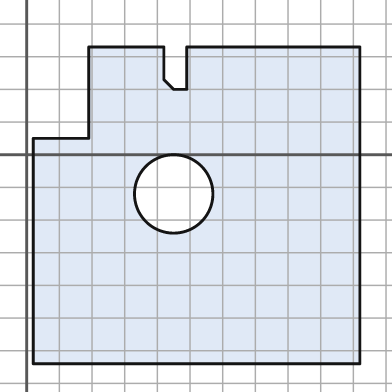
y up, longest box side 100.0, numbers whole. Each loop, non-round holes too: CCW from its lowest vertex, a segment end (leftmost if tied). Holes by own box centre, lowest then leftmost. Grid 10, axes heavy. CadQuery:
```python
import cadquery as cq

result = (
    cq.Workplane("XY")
    .moveTo(2.0, -64.0)
    .lineTo(102.0, -64.0)
    .lineTo(102.0, 33.0)
    .lineTo(49.0, 33.0)
    .lineTo(49.0, 20.0)
    .lineTo(45.0, 20.0)
    .lineTo(42.0, 23.0)
    .lineTo(42.0, 33.0)
    .lineTo(19.0, 33.0)
    .lineTo(19.0, 5.0)
    .lineTo(2.0, 5.0)
    .close()
    .moveTo(45.0, -12.0)
    .circle(12.0)
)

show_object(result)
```